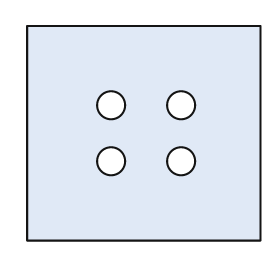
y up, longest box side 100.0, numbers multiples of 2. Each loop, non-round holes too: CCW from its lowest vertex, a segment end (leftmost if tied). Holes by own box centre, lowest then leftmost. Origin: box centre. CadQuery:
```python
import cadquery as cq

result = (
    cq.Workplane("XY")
    .moveTo(-50.0, -46.0)
    .lineTo(50.0, -46.0)
    .lineTo(50.0, 46.0)
    .lineTo(-50.0, 46.0)
    .close()
    .moveTo(-14.0, -12.0)
    .circle(6.0)
    .moveTo(16.0, -12.0)
    .circle(6.0)
    .moveTo(-14.0, 12.0)
    .circle(6.0)
    .moveTo(16.0, 12.0)
    .circle(6.0)
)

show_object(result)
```